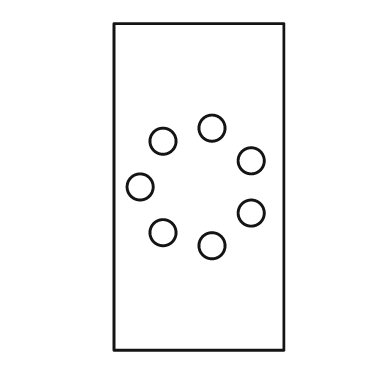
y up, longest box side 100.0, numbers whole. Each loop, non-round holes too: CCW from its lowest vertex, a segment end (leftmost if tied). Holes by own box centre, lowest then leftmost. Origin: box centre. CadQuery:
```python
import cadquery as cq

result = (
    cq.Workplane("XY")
    .moveTo(-26.0, -50.0)
    .lineTo(26.0, -50.0)
    .lineTo(26.0, 50.0)
    .lineTo(-26.0, 50.0)
    .close()
    .moveTo(4.0, -18.0)
    .circle(4.0)
    .moveTo(-11.0, -14.0)
    .circle(4.0)
    .moveTo(16.0, -8.0)
    .circle(4.0)
    .moveTo(-18.0, 0.0)
    .circle(4.0)
    .moveTo(16.0, 8.0)
    .circle(4.0)
    .moveTo(-11.0, 14.0)
    .circle(4.0)
    .moveTo(4.0, 18.0)
    .circle(4.0)
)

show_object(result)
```